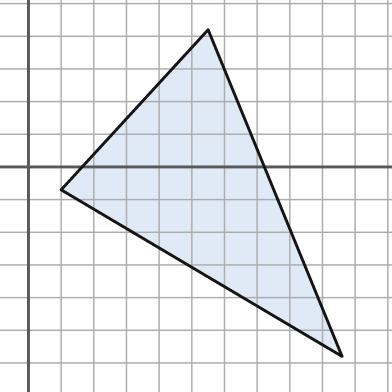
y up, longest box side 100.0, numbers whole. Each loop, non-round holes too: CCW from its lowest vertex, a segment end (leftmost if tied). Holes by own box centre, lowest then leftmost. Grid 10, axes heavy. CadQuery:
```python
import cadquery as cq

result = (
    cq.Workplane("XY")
    .moveTo(96.0, -58.0)
    .lineTo(55.0, 42.0)
    .lineTo(10.0, -7.0)
    .close()
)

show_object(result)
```